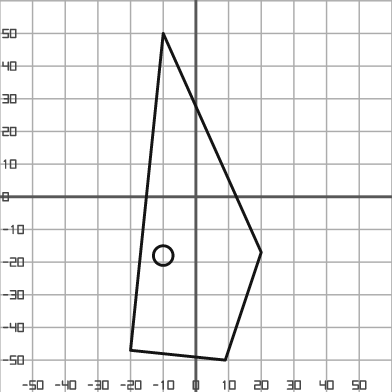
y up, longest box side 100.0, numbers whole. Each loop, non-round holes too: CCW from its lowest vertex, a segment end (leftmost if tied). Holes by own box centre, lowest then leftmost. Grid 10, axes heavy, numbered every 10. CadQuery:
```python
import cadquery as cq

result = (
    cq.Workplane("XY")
    .moveTo(9.0, -50.0)
    .lineTo(20.0, -17.0)
    .lineTo(-10.0, 50.0)
    .lineTo(-20.0, -47.0)
    .close()
    .moveTo(-10.0, -18.0)
    .circle(3.0)
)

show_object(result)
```